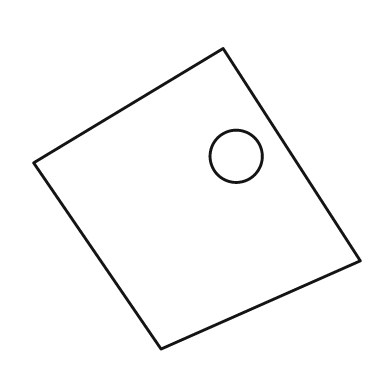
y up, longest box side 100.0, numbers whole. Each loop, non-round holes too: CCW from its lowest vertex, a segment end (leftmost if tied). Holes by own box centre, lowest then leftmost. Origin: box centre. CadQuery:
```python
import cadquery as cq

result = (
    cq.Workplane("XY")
    .moveTo(-11.0, -46.0)
    .lineTo(50.0, -19.0)
    .lineTo(8.0, 46.0)
    .lineTo(-50.0, 11.0)
    .close()
    .moveTo(12.0, 13.0)
    .circle(8.0)
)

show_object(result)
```